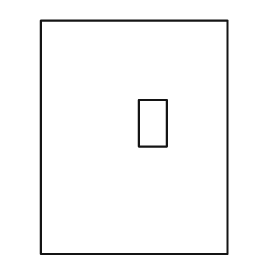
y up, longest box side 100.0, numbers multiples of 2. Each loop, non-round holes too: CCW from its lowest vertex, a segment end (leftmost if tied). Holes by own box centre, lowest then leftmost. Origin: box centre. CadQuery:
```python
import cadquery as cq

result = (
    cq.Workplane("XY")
    .moveTo(-40.0, -50.0)
    .lineTo(40.0, -50.0)
    .lineTo(40.0, 50.0)
    .lineTo(-40.0, 50.0)
    .close()
    .moveTo(2.0, -4.0)
    .lineTo(14.0, -4.0)
    .lineTo(14.0, 16.0)
    .lineTo(2.0, 16.0)
    .close()
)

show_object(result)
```